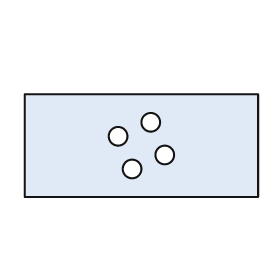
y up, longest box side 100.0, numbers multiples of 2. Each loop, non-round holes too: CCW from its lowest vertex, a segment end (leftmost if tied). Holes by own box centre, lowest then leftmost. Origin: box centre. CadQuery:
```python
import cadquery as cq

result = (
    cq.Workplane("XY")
    .moveTo(-50.0, -22.0)
    .lineTo(50.0, -22.0)
    .lineTo(50.0, 22.0)
    .lineTo(-50.0, 22.0)
    .close()
    .moveTo(-4.0, -10.0)
    .circle(4.0)
    .moveTo(10.0, -4.0)
    .circle(4.0)
    .moveTo(-10.0, 4.0)
    .circle(4.0)
    .moveTo(4.0, 10.0)
    .circle(4.0)
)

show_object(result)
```